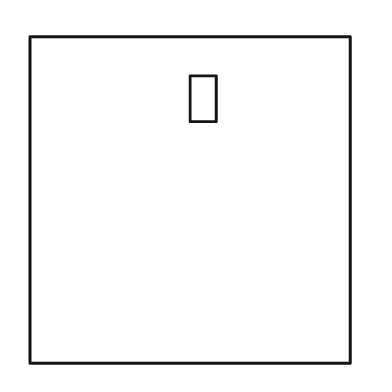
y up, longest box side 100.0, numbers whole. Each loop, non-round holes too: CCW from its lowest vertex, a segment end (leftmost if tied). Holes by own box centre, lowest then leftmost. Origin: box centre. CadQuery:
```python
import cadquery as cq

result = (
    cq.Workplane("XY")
    .moveTo(-49.0, -50.0)
    .lineTo(49.0, -50.0)
    .lineTo(49.0, 50.0)
    .lineTo(-49.0, 50.0)
    .close()
    .moveTo(0.0, 24.0)
    .lineTo(8.0, 24.0)
    .lineTo(8.0, 38.0)
    .lineTo(0.0, 38.0)
    .close()
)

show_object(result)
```